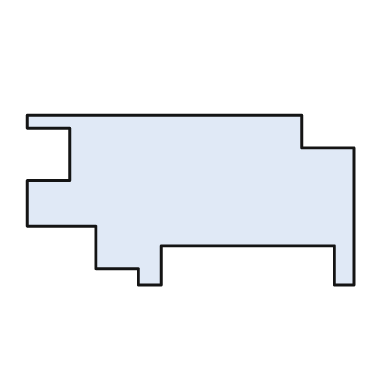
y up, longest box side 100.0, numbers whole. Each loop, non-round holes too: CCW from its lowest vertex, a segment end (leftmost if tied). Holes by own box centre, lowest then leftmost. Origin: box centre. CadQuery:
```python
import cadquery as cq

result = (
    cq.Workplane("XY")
    .moveTo(-16.0, -26.0)
    .lineTo(-9.0, -26.0)
    .lineTo(-9.0, -14.0)
    .lineTo(44.0, -14.0)
    .lineTo(44.0, -26.0)
    .lineTo(50.0, -26.0)
    .lineTo(50.0, 16.0)
    .lineTo(34.0, 16.0)
    .lineTo(34.0, 26.0)
    .lineTo(-50.0, 26.0)
    .lineTo(-50.0, 22.0)
    .lineTo(-37.0, 22.0)
    .lineTo(-37.0, 6.0)
    .lineTo(-50.0, 6.0)
    .lineTo(-50.0, -8.0)
    .lineTo(-29.0, -8.0)
    .lineTo(-29.0, -21.0)
    .lineTo(-16.0, -21.0)
    .close()
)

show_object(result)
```